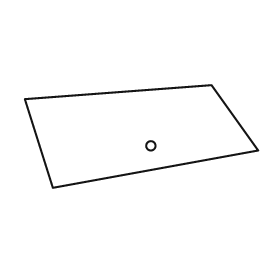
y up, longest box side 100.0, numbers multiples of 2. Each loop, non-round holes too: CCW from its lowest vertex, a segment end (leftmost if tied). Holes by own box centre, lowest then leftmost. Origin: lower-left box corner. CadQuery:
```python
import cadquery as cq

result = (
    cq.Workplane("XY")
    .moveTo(12.0, 0.0)
    .lineTo(100.0, 16.0)
    .lineTo(80.0, 44.0)
    .lineTo(0.0, 38.0)
    .close()
    .moveTo(54.0, 18.0)
    .circle(2.0)
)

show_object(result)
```